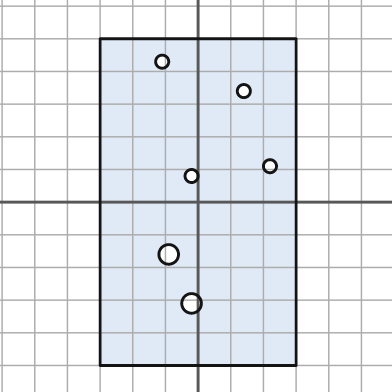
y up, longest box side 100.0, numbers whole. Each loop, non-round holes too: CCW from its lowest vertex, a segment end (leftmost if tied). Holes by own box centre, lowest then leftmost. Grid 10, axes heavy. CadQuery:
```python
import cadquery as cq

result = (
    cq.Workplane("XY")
    .moveTo(-30.0, -50.0)
    .lineTo(30.0, -50.0)
    .lineTo(30.0, 50.0)
    .lineTo(-30.0, 50.0)
    .close()
    .moveTo(-2.0, -31.0)
    .circle(3.0)
    .moveTo(-9.0, -16.0)
    .circle(3.0)
    .moveTo(-2.0, 8.0)
    .circle(2.0)
    .moveTo(22.0, 11.0)
    .circle(2.0)
    .moveTo(14.0, 34.0)
    .circle(2.0)
    .moveTo(-11.0, 43.0)
    .circle(2.0)
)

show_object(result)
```